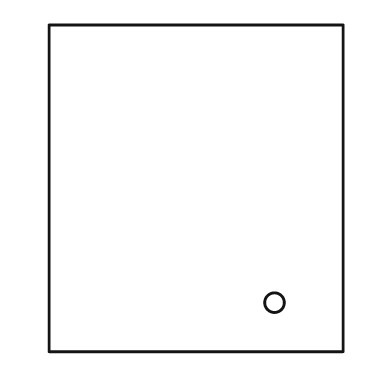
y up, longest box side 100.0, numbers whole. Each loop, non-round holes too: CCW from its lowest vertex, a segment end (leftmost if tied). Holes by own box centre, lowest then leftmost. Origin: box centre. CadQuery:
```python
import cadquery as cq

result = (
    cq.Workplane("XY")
    .moveTo(-45.0, -50.0)
    .lineTo(45.0, -50.0)
    .lineTo(45.0, 50.0)
    .lineTo(-45.0, 50.0)
    .close()
    .moveTo(24.0, -35.0)
    .circle(3.0)
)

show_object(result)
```